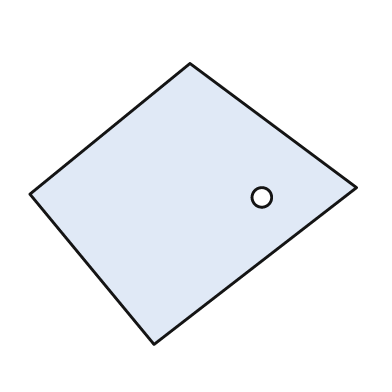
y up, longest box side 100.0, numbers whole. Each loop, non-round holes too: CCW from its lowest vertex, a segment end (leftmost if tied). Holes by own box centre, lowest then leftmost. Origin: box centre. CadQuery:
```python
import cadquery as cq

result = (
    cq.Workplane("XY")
    .moveTo(-12.0, -43.0)
    .lineTo(50.0, 5.0)
    .lineTo(-1.0, 43.0)
    .lineTo(-50.0, 3.0)
    .close()
    .moveTo(21.0, 2.0)
    .circle(3.0)
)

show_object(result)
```